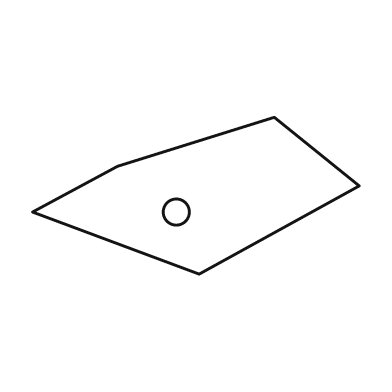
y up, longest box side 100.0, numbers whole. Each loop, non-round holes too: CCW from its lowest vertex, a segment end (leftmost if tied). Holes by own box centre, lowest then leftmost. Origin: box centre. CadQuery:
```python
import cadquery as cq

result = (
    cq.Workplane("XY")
    .moveTo(1.0, -24.0)
    .lineTo(50.0, 3.0)
    .lineTo(24.0, 24.0)
    .lineTo(-24.0, 9.0)
    .lineTo(-50.0, -5.0)
    .close()
    .moveTo(-6.0, -5.0)
    .circle(4.0)
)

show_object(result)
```